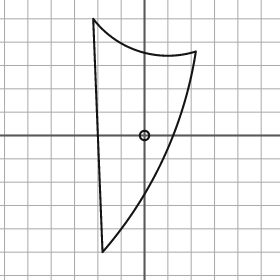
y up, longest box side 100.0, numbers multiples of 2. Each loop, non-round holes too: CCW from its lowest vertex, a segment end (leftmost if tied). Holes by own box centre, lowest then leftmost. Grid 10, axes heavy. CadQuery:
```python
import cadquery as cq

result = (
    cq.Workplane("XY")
    .moveTo(-18.0, -50.0)
    .threePointArc((8.0, -10.0), (22.0, 36.0))
    .threePointArc((-2.0, 36.0), (-22.0, 50.0))
    .close()
    .moveTo(0.0, 0.0)
    .circle(2.0)
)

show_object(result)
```